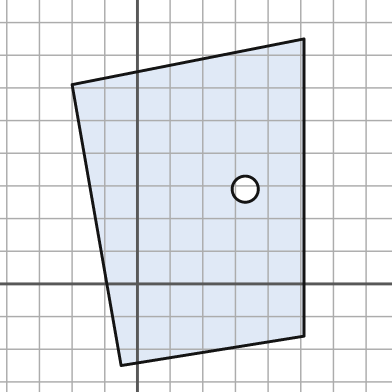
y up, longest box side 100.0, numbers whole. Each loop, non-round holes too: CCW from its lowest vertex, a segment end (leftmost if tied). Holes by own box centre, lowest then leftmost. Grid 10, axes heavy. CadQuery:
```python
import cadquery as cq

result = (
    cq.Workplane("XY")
    .moveTo(-5.0, -25.0)
    .lineTo(51.0, -16.0)
    .lineTo(51.0, 75.0)
    .lineTo(-20.0, 61.0)
    .close()
    .moveTo(33.0, 29.0)
    .circle(4.0)
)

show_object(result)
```